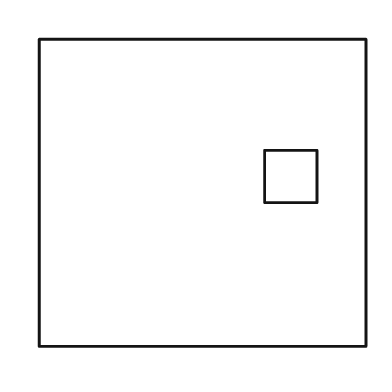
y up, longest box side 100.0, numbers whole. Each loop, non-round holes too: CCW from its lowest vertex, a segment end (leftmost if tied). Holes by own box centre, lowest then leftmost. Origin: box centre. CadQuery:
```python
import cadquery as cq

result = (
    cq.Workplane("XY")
    .moveTo(-50.0, -47.0)
    .lineTo(50.0, -47.0)
    .lineTo(50.0, 47.0)
    .lineTo(-50.0, 47.0)
    .close()
    .moveTo(19.0, -3.0)
    .lineTo(35.0, -3.0)
    .lineTo(35.0, 13.0)
    .lineTo(19.0, 13.0)
    .close()
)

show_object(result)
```